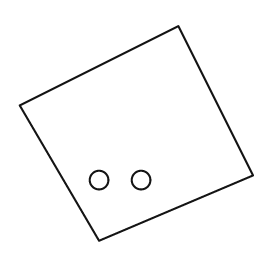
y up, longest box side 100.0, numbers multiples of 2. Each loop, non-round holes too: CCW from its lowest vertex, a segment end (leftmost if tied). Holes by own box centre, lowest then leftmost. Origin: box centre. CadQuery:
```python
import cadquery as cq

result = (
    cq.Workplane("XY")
    .moveTo(-16.0, -46.0)
    .lineTo(50.0, -18.0)
    .lineTo(18.0, 46.0)
    .lineTo(-50.0, 12.0)
    .close()
    .moveTo(-16.0, -20.0)
    .circle(4.0)
    .moveTo(2.0, -20.0)
    .circle(4.0)
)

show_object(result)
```